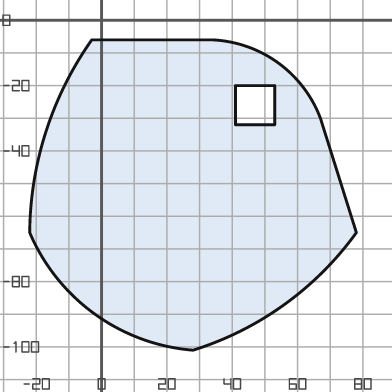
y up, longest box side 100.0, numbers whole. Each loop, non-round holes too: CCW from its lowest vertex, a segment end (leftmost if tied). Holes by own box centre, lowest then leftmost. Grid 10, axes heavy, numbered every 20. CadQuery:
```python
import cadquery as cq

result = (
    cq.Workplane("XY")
    .moveTo(28.0, -101.0)
    .threePointArc((56.0, -87.0), (78.0, -65.0))
    .lineTo(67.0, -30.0)
    .threePointArc((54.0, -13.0), (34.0, -6.0))
    .lineTo(-3.0, -6.0)
    .threePointArc((-17.0, -34.0), (-22.0, -65.0))
    .threePointArc((-2.0, -90.0), (28.0, -101.0))
    .close()
    .moveTo(41.0, -32.0)
    .lineTo(53.0, -32.0)
    .lineTo(53.0, -20.0)
    .lineTo(41.0, -20.0)
    .close()
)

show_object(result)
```